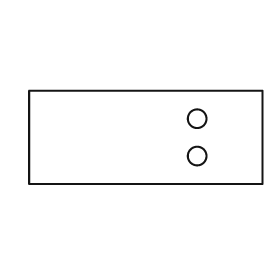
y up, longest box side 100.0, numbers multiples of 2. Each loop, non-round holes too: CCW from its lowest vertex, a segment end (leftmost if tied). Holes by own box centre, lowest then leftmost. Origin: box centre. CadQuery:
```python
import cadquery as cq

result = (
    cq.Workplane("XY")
    .moveTo(-50.0, -20.0)
    .lineTo(50.0, -20.0)
    .lineTo(50.0, 20.0)
    .lineTo(-50.0, 20.0)
    .close()
    .moveTo(22.0, -8.0)
    .circle(4.0)
    .moveTo(22.0, 8.0)
    .circle(4.0)
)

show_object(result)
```